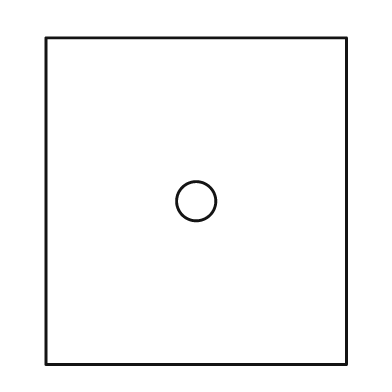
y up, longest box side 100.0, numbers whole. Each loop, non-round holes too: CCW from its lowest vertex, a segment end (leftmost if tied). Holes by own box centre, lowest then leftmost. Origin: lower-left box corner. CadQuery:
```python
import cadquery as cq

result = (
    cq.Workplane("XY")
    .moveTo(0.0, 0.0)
    .lineTo(92.0, 0.0)
    .lineTo(92.0, 100.0)
    .lineTo(0.0, 100.0)
    .close()
    .moveTo(46.0, 50.0)
    .circle(6.0)
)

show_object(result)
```